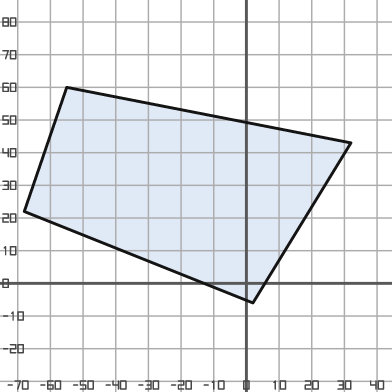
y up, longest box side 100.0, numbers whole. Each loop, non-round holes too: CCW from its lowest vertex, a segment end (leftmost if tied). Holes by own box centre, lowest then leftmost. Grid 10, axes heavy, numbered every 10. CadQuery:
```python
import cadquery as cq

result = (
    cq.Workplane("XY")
    .moveTo(2.0, -6.0)
    .lineTo(32.0, 43.0)
    .lineTo(-55.0, 60.0)
    .lineTo(-68.0, 22.0)
    .close()
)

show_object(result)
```